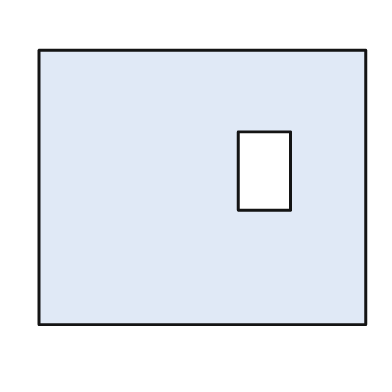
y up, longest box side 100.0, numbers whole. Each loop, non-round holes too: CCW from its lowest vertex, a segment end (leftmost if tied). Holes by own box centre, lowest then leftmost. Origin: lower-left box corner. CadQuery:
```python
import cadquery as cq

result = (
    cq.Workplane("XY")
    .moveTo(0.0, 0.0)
    .lineTo(100.0, 0.0)
    .lineTo(100.0, 84.0)
    .lineTo(0.0, 84.0)
    .close()
    .moveTo(61.0, 35.0)
    .lineTo(77.0, 35.0)
    .lineTo(77.0, 59.0)
    .lineTo(61.0, 59.0)
    .close()
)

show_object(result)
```